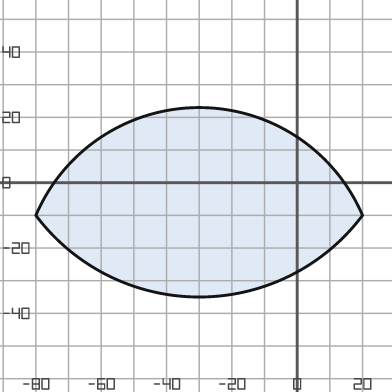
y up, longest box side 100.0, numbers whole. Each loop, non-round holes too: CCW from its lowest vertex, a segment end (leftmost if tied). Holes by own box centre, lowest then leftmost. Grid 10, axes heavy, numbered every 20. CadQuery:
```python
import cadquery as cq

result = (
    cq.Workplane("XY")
    .moveTo(-80.0, -10.0)
    .threePointArc((-30.0, -35.0), (20.0, -10.0))
    .threePointArc((-30.0, 23.0), (-80.0, -10.0))
    .close()
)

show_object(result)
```